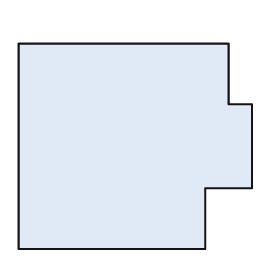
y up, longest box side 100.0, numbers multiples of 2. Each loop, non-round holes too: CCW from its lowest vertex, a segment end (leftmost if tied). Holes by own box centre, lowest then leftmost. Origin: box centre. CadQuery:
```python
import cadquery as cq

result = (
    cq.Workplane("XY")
    .moveTo(-50.0, -44.0)
    .lineTo(30.0, -44.0)
    .lineTo(30.0, -18.0)
    .lineTo(50.0, -18.0)
    .lineTo(50.0, 18.0)
    .lineTo(40.0, 18.0)
    .lineTo(40.0, 44.0)
    .lineTo(-50.0, 44.0)
    .close()
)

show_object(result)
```